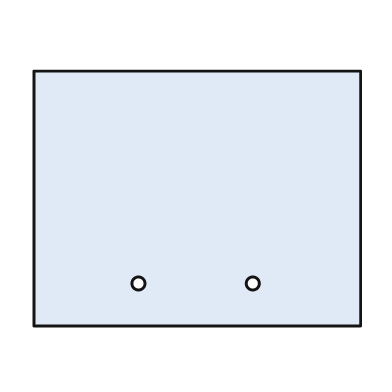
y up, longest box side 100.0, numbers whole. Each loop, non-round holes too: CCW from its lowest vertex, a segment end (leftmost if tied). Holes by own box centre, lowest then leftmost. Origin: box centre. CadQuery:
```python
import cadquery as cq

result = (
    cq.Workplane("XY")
    .moveTo(-50.0, -39.0)
    .lineTo(50.0, -39.0)
    .lineTo(50.0, 39.0)
    .lineTo(-50.0, 39.0)
    .close()
    .moveTo(-18.0, -26.0)
    .circle(2.0)
    .moveTo(17.0, -26.0)
    .circle(2.0)
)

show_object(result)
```